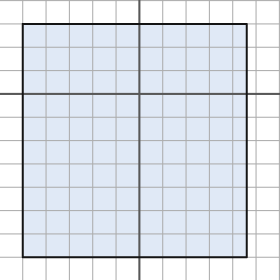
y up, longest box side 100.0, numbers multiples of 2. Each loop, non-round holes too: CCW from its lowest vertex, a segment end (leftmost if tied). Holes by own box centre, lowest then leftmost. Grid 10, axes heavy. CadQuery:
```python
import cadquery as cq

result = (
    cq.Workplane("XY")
    .moveTo(-50.0, -70.0)
    .lineTo(46.0, -70.0)
    .lineTo(46.0, 30.0)
    .lineTo(-50.0, 30.0)
    .close()
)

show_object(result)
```